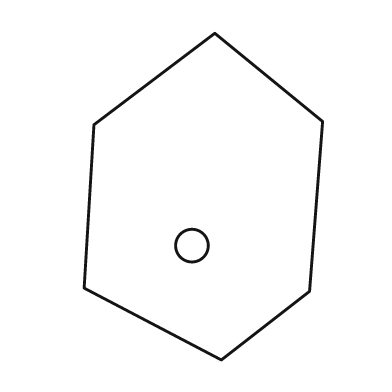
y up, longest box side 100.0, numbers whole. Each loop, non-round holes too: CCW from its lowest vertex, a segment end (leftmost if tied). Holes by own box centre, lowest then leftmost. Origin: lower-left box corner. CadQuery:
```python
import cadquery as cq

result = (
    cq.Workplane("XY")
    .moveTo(42.0, 0.0)
    .lineTo(69.0, 21.0)
    .lineTo(73.0, 73.0)
    .lineTo(40.0, 100.0)
    .lineTo(3.0, 72.0)
    .lineTo(0.0, 22.0)
    .close()
    .moveTo(33.0, 35.0)
    .circle(5.0)
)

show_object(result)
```